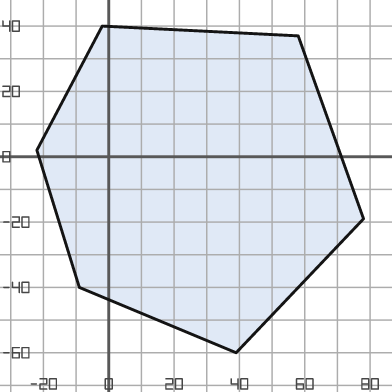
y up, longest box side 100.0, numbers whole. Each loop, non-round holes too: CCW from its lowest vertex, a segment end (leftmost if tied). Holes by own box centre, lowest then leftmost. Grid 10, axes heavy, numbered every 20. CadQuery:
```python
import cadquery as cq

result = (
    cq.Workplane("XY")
    .moveTo(39.0, -60.0)
    .lineTo(78.0, -19.0)
    .lineTo(58.0, 37.0)
    .lineTo(-2.0, 40.0)
    .lineTo(-22.0, 2.0)
    .lineTo(-9.0, -40.0)
    .close()
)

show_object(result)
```